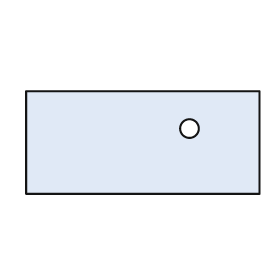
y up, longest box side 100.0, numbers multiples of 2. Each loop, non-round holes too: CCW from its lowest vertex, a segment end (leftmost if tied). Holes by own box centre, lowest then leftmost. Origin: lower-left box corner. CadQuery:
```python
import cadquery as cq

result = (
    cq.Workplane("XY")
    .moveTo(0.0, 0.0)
    .lineTo(100.0, 0.0)
    .lineTo(100.0, 44.0)
    .lineTo(0.0, 44.0)
    .close()
    .moveTo(70.0, 28.0)
    .circle(4.0)
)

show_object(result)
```